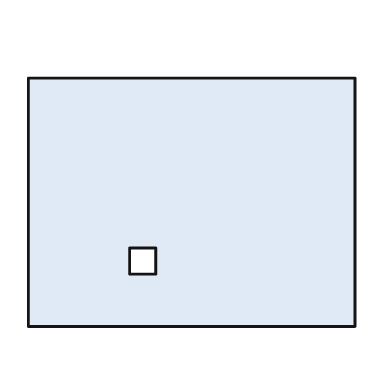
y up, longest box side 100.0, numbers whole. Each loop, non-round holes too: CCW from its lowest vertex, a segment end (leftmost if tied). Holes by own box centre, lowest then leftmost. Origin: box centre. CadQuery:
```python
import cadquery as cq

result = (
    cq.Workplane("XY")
    .moveTo(-50.0, -38.0)
    .lineTo(50.0, -38.0)
    .lineTo(50.0, 38.0)
    .lineTo(-50.0, 38.0)
    .close()
    .moveTo(-19.0, -22.0)
    .lineTo(-11.0, -22.0)
    .lineTo(-11.0, -14.0)
    .lineTo(-19.0, -14.0)
    .close()
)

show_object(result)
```